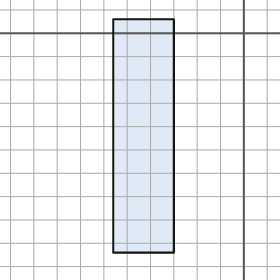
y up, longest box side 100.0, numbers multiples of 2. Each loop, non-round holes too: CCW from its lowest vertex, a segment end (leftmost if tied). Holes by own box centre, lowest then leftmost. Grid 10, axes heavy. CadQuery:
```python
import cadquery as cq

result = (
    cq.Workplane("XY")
    .moveTo(-56.0, -94.0)
    .lineTo(-30.0, -94.0)
    .lineTo(-30.0, 6.0)
    .lineTo(-56.0, 6.0)
    .close()
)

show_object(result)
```